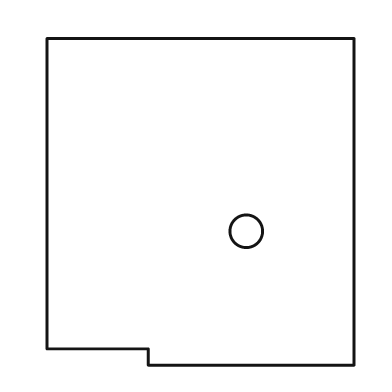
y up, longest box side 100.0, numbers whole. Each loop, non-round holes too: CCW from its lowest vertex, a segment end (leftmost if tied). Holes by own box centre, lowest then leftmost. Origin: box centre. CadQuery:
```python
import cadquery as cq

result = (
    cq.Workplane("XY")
    .moveTo(-16.0, -50.0)
    .lineTo(47.0, -50.0)
    .lineTo(47.0, 50.0)
    .lineTo(-47.0, 50.0)
    .lineTo(-47.0, -45.0)
    .lineTo(-16.0, -45.0)
    .close()
    .moveTo(14.0, -9.0)
    .circle(5.0)
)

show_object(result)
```